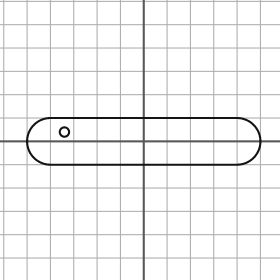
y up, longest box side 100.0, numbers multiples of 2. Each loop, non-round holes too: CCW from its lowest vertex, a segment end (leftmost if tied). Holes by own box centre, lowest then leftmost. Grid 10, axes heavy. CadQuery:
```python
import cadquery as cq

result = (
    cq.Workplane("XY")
    .moveTo(-40.0, -10.0)
    .lineTo(40.0, -10.0)
    .threePointArc((50.0, 0.0), (40.0, 10.0))
    .lineTo(-40.0, 10.0)
    .threePointArc((-50.0, 0.0), (-40.0, -10.0))
    .close()
    .moveTo(-34.0, 4.0)
    .circle(2.0)
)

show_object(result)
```